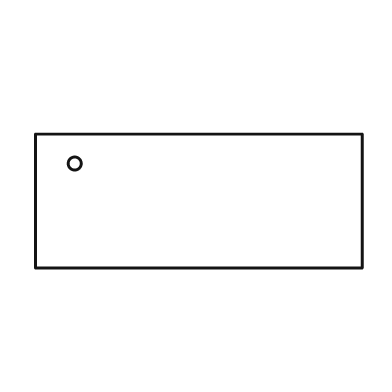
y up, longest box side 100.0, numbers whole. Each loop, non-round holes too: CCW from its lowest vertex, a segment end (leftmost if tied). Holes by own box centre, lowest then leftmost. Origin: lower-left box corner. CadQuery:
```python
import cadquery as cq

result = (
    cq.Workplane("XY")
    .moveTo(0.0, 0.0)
    .lineTo(100.0, 0.0)
    .lineTo(100.0, 41.0)
    .lineTo(0.0, 41.0)
    .close()
    .moveTo(12.0, 32.0)
    .circle(2.0)
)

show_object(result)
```